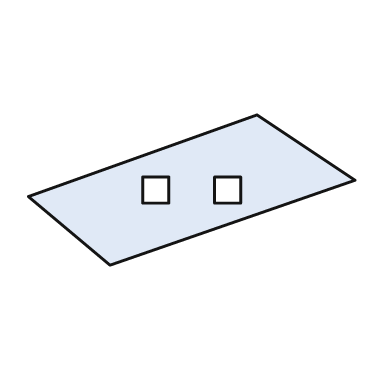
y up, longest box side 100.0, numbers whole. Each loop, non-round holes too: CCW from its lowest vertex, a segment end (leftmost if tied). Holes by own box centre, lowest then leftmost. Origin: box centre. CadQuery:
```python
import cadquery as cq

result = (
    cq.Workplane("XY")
    .moveTo(-25.0, -23.0)
    .lineTo(50.0, 3.0)
    .lineTo(20.0, 23.0)
    .lineTo(-50.0, -2.0)
    .close()
    .moveTo(-15.0, -4.0)
    .lineTo(-7.0, -4.0)
    .lineTo(-7.0, 4.0)
    .lineTo(-15.0, 4.0)
    .close()
    .moveTo(7.0, -4.0)
    .lineTo(15.0, -4.0)
    .lineTo(15.0, 4.0)
    .lineTo(7.0, 4.0)
    .close()
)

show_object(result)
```